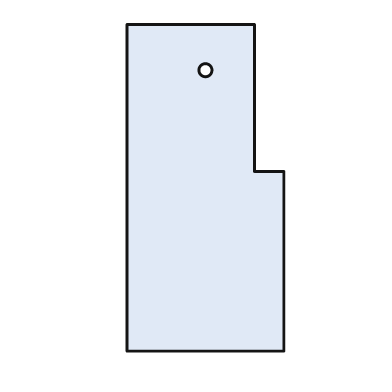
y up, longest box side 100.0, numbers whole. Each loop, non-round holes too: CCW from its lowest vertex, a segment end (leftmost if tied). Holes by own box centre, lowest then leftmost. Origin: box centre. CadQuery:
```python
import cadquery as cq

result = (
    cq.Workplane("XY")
    .moveTo(-24.0, -50.0)
    .lineTo(24.0, -50.0)
    .lineTo(24.0, 5.0)
    .lineTo(15.0, 5.0)
    .lineTo(15.0, 50.0)
    .lineTo(-24.0, 50.0)
    .close()
    .moveTo(0.0, 36.0)
    .circle(2.0)
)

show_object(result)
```